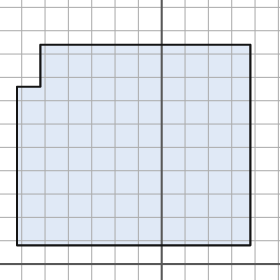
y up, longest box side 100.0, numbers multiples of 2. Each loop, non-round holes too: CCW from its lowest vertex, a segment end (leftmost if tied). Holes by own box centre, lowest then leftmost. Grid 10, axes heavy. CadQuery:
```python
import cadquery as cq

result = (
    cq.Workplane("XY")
    .moveTo(-62.0, 8.0)
    .lineTo(38.0, 8.0)
    .lineTo(38.0, 94.0)
    .lineTo(-52.0, 94.0)
    .lineTo(-52.0, 76.0)
    .lineTo(-62.0, 76.0)
    .close()
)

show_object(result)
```